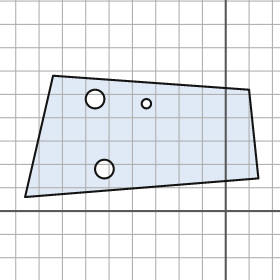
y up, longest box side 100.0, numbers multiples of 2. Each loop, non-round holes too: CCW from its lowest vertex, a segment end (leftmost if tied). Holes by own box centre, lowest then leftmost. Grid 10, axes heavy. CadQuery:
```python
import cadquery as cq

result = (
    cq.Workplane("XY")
    .moveTo(-86.0, 6.0)
    .lineTo(14.0, 14.0)
    .lineTo(10.0, 52.0)
    .lineTo(-74.0, 58.0)
    .close()
    .moveTo(-52.0, 18.0)
    .circle(4.0)
    .moveTo(-34.0, 46.0)
    .circle(2.0)
    .moveTo(-56.0, 48.0)
    .circle(4.0)
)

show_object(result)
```